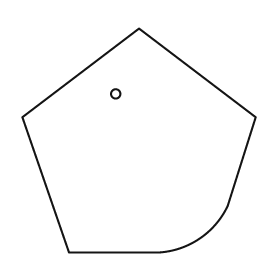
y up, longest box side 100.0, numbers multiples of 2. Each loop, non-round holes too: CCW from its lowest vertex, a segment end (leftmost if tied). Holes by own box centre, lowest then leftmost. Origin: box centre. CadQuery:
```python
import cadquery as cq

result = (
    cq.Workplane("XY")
    .moveTo(-30.0, -48.0)
    .lineTo(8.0, -48.0)
    .threePointArc((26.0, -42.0), (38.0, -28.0))
    .lineTo(50.0, 10.0)
    .lineTo(0.0, 48.0)
    .lineTo(-50.0, 10.0)
    .close()
    .moveTo(-10.0, 20.0)
    .circle(2.0)
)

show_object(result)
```